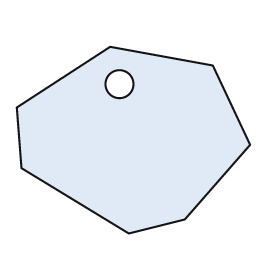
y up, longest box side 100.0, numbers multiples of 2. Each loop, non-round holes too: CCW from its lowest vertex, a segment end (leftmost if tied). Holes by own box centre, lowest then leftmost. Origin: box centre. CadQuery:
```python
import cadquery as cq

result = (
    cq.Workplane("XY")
    .moveTo(-2.0, -40.0)
    .lineTo(22.0, -34.0)
    .lineTo(50.0, -2.0)
    .lineTo(34.0, 32.0)
    .lineTo(-10.0, 40.0)
    .lineTo(-50.0, 14.0)
    .lineTo(-48.0, -12.0)
    .close()
    .moveTo(-6.0, 24.0)
    .circle(6.0)
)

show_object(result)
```